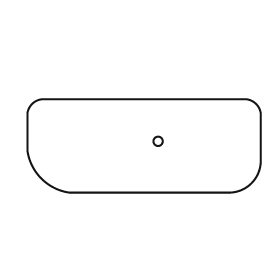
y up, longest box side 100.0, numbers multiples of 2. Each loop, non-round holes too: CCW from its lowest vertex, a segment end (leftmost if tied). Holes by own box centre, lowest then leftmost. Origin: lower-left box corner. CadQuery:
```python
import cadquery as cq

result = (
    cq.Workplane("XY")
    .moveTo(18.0, 0.0)
    .lineTo(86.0, 0.0)
    .threePointArc((96.0, 4.0), (100.0, 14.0))
    .lineTo(100.0, 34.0)
    .threePointArc((98.0, 38.0), (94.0, 40.0))
    .lineTo(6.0, 40.0)
    .threePointArc((2.0, 38.0), (0.0, 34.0))
    .lineTo(0.0, 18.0)
    .threePointArc((6.0, 6.0), (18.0, 0.0))
    .close()
    .moveTo(56.0, 22.0)
    .circle(2.0)
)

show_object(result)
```